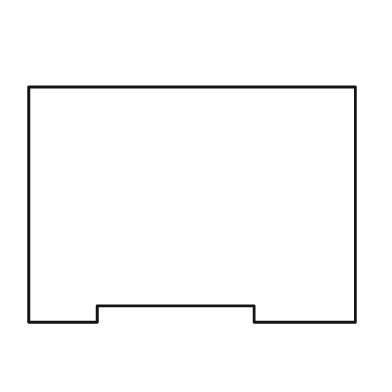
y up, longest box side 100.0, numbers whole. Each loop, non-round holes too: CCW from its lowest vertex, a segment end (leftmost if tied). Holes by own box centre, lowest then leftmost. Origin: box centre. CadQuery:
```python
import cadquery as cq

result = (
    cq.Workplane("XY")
    .moveTo(-50.0, -36.0)
    .lineTo(-29.0, -36.0)
    .lineTo(-29.0, -31.0)
    .lineTo(19.0, -31.0)
    .lineTo(19.0, -36.0)
    .lineTo(50.0, -36.0)
    .lineTo(50.0, 36.0)
    .lineTo(-50.0, 36.0)
    .close()
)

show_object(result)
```